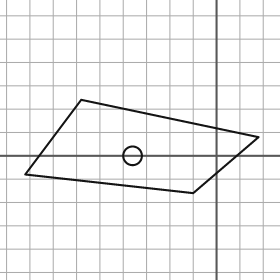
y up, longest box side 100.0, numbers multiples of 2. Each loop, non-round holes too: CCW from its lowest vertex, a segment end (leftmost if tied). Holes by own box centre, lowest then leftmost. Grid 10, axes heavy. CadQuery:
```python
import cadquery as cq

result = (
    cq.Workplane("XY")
    .moveTo(-10.0, -16.0)
    .lineTo(18.0, 8.0)
    .lineTo(-58.0, 24.0)
    .lineTo(-82.0, -8.0)
    .close()
    .moveTo(-36.0, 0.0)
    .circle(4.0)
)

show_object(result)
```